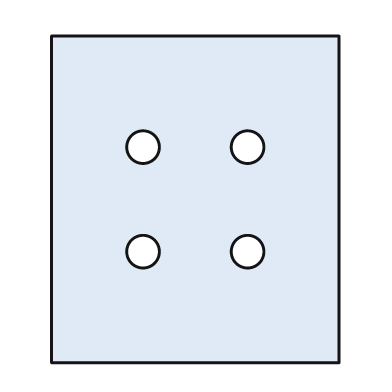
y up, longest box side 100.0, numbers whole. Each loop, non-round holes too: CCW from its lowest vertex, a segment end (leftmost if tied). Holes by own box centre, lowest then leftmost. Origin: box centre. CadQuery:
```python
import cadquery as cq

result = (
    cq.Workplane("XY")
    .moveTo(-44.0, -50.0)
    .lineTo(44.0, -50.0)
    .lineTo(44.0, 50.0)
    .lineTo(-44.0, 50.0)
    .close()
    .moveTo(-16.0, -16.0)
    .circle(5.0)
    .moveTo(16.0, -16.0)
    .circle(5.0)
    .moveTo(-16.0, 16.0)
    .circle(5.0)
    .moveTo(16.0, 16.0)
    .circle(5.0)
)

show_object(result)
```